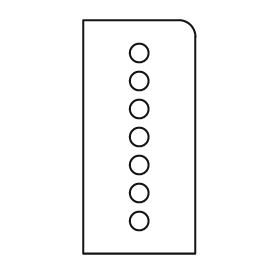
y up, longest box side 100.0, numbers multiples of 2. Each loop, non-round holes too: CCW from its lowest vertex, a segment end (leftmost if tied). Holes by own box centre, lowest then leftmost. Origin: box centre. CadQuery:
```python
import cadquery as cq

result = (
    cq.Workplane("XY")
    .moveTo(-24.0, -50.0)
    .lineTo(24.0, -50.0)
    .lineTo(24.0, 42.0)
    .threePointArc((22.0, 48.0), (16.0, 50.0))
    .lineTo(-24.0, 50.0)
    .close()
    .moveTo(0.0, -36.0)
    .circle(4.0)
    .moveTo(0.0, -24.0)
    .circle(4.0)
    .moveTo(0.0, -12.0)
    .circle(4.0)
    .moveTo(0.0, 0.0)
    .circle(4.0)
    .moveTo(0.0, 12.0)
    .circle(4.0)
    .moveTo(0.0, 24.0)
    .circle(4.0)
    .moveTo(0.0, 36.0)
    .circle(4.0)
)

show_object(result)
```